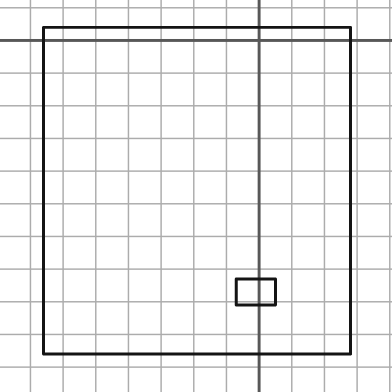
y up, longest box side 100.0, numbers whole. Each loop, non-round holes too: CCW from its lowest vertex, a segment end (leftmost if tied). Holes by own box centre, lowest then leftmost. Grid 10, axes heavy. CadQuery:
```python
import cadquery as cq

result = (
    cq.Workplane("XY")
    .moveTo(-66.0, -96.0)
    .lineTo(28.0, -96.0)
    .lineTo(28.0, 4.0)
    .lineTo(-66.0, 4.0)
    .close()
    .moveTo(-7.0, -81.0)
    .lineTo(5.0, -81.0)
    .lineTo(5.0, -73.0)
    .lineTo(-7.0, -73.0)
    .close()
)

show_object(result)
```